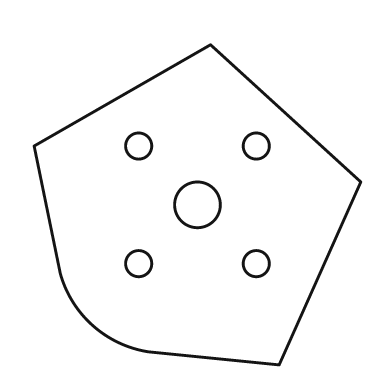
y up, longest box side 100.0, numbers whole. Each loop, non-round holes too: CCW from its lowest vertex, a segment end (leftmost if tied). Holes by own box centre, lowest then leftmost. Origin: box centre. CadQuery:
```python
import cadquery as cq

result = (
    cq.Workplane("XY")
    .moveTo(25.0, -49.0)
    .lineTo(50.0, 7.0)
    .lineTo(4.0, 49.0)
    .lineTo(-50.0, 18.0)
    .lineTo(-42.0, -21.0)
    .threePointArc((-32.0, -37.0), (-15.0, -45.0))
    .close()
    .moveTo(-18.0, -18.0)
    .circle(4.0)
    .moveTo(18.0, -18.0)
    .circle(4.0)
    .moveTo(0.0, 0.0)
    .circle(7.0)
    .moveTo(-18.0, 18.0)
    .circle(4.0)
    .moveTo(18.0, 18.0)
    .circle(4.0)
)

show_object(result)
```